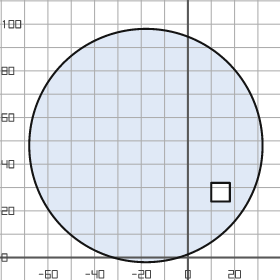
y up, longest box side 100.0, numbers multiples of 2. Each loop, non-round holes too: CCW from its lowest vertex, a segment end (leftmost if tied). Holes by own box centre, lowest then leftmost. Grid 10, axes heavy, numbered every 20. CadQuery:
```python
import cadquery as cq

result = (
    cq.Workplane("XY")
    .moveTo(-18.0, 48.0)
    .circle(50.0)
    .moveTo(10.0, 24.0)
    .lineTo(18.0, 24.0)
    .lineTo(18.0, 32.0)
    .lineTo(10.0, 32.0)
    .close()
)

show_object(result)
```